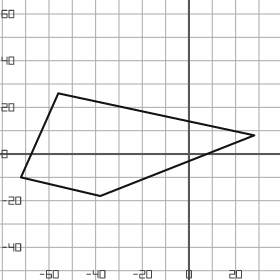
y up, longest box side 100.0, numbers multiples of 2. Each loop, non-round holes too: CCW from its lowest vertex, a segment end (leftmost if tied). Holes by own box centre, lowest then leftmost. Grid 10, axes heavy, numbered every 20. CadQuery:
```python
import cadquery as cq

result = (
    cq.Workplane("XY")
    .moveTo(-38.0, -18.0)
    .lineTo(28.0, 8.0)
    .lineTo(-56.0, 26.0)
    .lineTo(-72.0, -10.0)
    .close()
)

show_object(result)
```